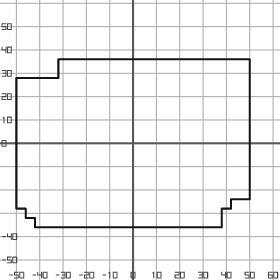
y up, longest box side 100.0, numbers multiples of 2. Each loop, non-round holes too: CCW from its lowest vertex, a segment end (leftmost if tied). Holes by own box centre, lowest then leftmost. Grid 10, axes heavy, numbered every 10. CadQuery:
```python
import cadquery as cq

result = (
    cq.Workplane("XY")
    .moveTo(-42.0, -36.0)
    .lineTo(38.0, -36.0)
    .lineTo(38.0, -28.0)
    .lineTo(42.0, -28.0)
    .lineTo(42.0, -24.0)
    .lineTo(50.0, -24.0)
    .lineTo(50.0, 36.0)
    .lineTo(-32.0, 36.0)
    .lineTo(-32.0, 28.0)
    .lineTo(-50.0, 28.0)
    .lineTo(-50.0, -28.0)
    .lineTo(-46.0, -28.0)
    .lineTo(-46.0, -32.0)
    .lineTo(-42.0, -32.0)
    .close()
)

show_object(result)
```